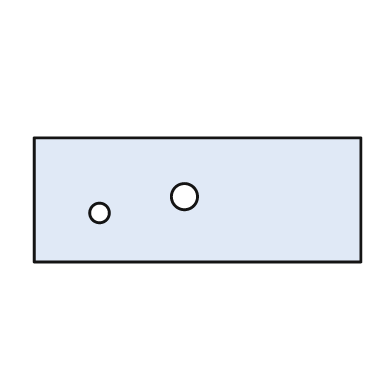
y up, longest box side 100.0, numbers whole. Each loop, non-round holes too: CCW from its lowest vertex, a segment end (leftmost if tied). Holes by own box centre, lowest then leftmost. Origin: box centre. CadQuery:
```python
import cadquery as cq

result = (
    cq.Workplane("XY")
    .moveTo(-50.0, -19.0)
    .lineTo(50.0, -19.0)
    .lineTo(50.0, 19.0)
    .lineTo(-50.0, 19.0)
    .close()
    .moveTo(-30.0, -4.0)
    .circle(3.0)
    .moveTo(-4.0, 1.0)
    .circle(4.0)
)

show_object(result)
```